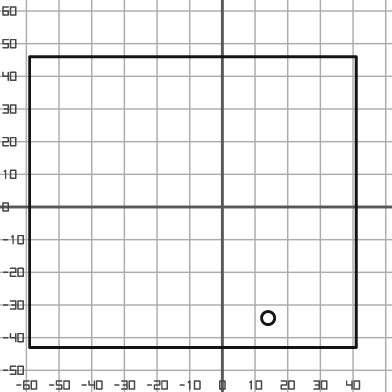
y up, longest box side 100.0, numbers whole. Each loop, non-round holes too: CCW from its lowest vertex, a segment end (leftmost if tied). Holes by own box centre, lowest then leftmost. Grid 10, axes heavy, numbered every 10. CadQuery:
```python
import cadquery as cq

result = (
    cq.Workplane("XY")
    .moveTo(-59.0, -43.0)
    .lineTo(41.0, -43.0)
    .lineTo(41.0, 46.0)
    .lineTo(-59.0, 46.0)
    .close()
    .moveTo(14.0, -34.0)
    .circle(2.0)
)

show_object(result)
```